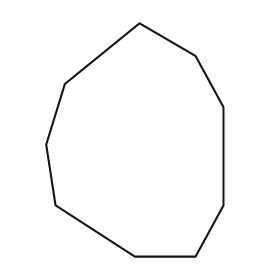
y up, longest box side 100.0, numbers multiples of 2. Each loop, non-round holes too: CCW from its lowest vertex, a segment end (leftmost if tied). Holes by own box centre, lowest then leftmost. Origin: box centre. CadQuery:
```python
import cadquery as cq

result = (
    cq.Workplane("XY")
    .moveTo(0.0, -50.0)
    .lineTo(26.0, -50.0)
    .lineTo(38.0, -28.0)
    .lineTo(38.0, 14.0)
    .lineTo(26.0, 36.0)
    .lineTo(2.0, 50.0)
    .lineTo(-30.0, 24.0)
    .lineTo(-38.0, -2.0)
    .lineTo(-34.0, -28.0)
    .close()
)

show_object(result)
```